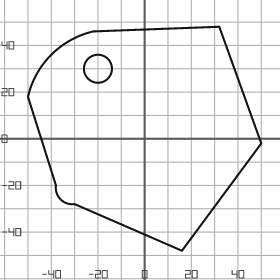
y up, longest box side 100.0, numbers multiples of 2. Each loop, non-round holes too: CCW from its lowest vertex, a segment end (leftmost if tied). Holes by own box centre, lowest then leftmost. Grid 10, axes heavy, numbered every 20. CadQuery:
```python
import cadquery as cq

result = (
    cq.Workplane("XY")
    .moveTo(16.0, -48.0)
    .lineTo(50.0, -2.0)
    .lineTo(32.0, 48.0)
    .lineTo(-22.0, 46.0)
    .threePointArc((-40.0, 36.0), (-50.0, 18.0))
    .lineTo(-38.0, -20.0)
    .threePointArc((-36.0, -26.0), (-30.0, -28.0))
    .close()
    .moveTo(-20.0, 30.0)
    .circle(6.0)
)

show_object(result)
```